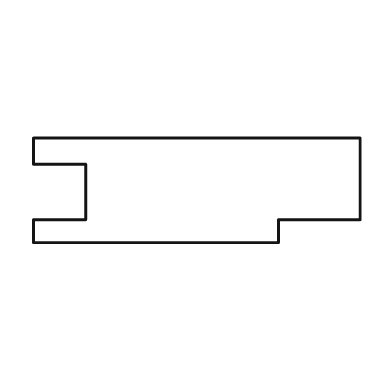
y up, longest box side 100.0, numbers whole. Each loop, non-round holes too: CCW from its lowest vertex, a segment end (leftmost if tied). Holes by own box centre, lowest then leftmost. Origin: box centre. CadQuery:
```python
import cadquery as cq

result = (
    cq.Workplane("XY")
    .moveTo(-50.0, -16.0)
    .lineTo(25.0, -16.0)
    .lineTo(25.0, -9.0)
    .lineTo(50.0, -9.0)
    .lineTo(50.0, 16.0)
    .lineTo(-50.0, 16.0)
    .lineTo(-50.0, 8.0)
    .lineTo(-34.0, 8.0)
    .lineTo(-34.0, -9.0)
    .lineTo(-50.0, -9.0)
    .close()
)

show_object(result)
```